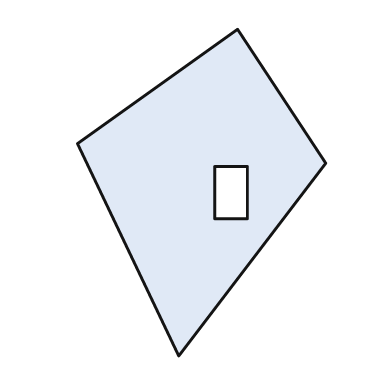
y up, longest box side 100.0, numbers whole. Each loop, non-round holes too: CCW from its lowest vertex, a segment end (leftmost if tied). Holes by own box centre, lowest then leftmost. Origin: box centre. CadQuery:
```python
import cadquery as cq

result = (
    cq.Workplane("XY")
    .moveTo(-7.0, -50.0)
    .lineTo(38.0, 9.0)
    .lineTo(11.0, 50.0)
    .lineTo(-38.0, 15.0)
    .close()
    .moveTo(4.0, -8.0)
    .lineTo(14.0, -8.0)
    .lineTo(14.0, 8.0)
    .lineTo(4.0, 8.0)
    .close()
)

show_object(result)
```